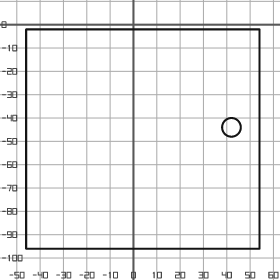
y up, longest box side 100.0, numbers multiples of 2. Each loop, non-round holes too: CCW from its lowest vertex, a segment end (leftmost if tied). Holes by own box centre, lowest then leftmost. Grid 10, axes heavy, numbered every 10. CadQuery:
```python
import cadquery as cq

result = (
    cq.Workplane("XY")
    .moveTo(-46.0, -96.0)
    .lineTo(54.0, -96.0)
    .lineTo(54.0, -2.0)
    .lineTo(-46.0, -2.0)
    .close()
    .moveTo(42.0, -44.0)
    .circle(4.0)
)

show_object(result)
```